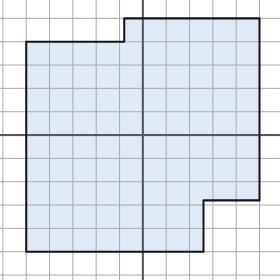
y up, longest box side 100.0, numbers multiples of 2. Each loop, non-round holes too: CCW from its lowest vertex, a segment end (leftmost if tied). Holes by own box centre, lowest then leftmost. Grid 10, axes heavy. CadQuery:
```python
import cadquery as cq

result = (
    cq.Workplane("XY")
    .moveTo(-50.0, -50.0)
    .lineTo(26.0, -50.0)
    .lineTo(26.0, -28.0)
    .lineTo(50.0, -28.0)
    .lineTo(50.0, 50.0)
    .lineTo(-8.0, 50.0)
    .lineTo(-8.0, 40.0)
    .lineTo(-50.0, 40.0)
    .close()
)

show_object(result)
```